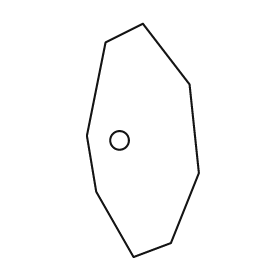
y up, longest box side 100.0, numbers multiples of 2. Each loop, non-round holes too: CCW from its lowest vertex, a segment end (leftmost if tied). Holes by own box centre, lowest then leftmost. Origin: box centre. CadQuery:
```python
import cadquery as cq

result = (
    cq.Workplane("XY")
    .moveTo(-4.0, -50.0)
    .lineTo(12.0, -44.0)
    .lineTo(24.0, -14.0)
    .lineTo(20.0, 24.0)
    .lineTo(0.0, 50.0)
    .lineTo(-16.0, 42.0)
    .lineTo(-24.0, 2.0)
    .lineTo(-20.0, -22.0)
    .close()
    .moveTo(-10.0, 0.0)
    .circle(4.0)
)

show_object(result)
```